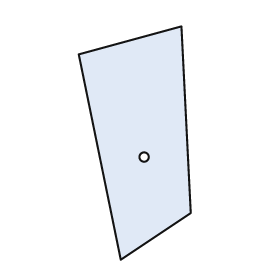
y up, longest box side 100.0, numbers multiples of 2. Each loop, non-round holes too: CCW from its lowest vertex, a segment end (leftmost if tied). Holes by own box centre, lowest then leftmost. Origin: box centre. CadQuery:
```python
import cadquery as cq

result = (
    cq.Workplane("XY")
    .moveTo(-6.0, -50.0)
    .lineTo(24.0, -30.0)
    .lineTo(20.0, 50.0)
    .lineTo(-24.0, 38.0)
    .close()
    .moveTo(4.0, -6.0)
    .circle(2.0)
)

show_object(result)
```